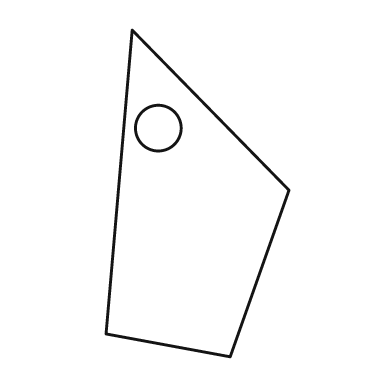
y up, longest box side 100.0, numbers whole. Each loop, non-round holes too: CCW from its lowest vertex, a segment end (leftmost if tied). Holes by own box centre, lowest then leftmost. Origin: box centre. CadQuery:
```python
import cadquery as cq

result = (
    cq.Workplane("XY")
    .moveTo(10.0, -50.0)
    .lineTo(28.0, 1.0)
    .lineTo(-20.0, 50.0)
    .lineTo(-28.0, -43.0)
    .close()
    .moveTo(-12.0, 20.0)
    .circle(7.0)
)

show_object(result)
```